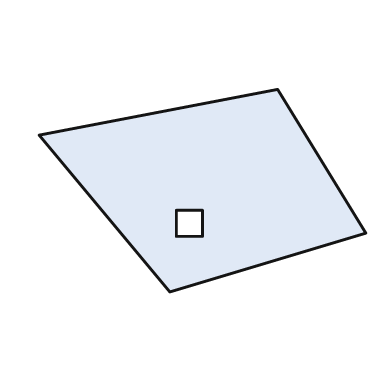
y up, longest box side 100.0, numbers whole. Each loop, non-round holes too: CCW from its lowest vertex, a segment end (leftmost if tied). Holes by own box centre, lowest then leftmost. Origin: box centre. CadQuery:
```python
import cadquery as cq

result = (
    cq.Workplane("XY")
    .moveTo(-10.0, -31.0)
    .lineTo(50.0, -13.0)
    .lineTo(23.0, 31.0)
    .lineTo(-50.0, 17.0)
    .close()
    .moveTo(-8.0, -14.0)
    .lineTo(0.0, -14.0)
    .lineTo(0.0, -6.0)
    .lineTo(-8.0, -6.0)
    .close()
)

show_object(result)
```